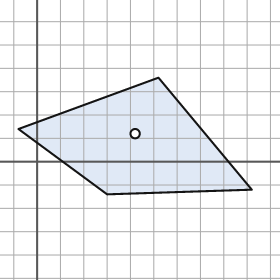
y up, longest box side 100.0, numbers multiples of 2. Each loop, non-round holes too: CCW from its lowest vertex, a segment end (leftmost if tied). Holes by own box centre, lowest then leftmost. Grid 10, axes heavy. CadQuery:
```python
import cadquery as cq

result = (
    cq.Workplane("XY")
    .moveTo(30.0, -14.0)
    .lineTo(92.0, -12.0)
    .lineTo(52.0, 36.0)
    .lineTo(-8.0, 14.0)
    .close()
    .moveTo(42.0, 12.0)
    .circle(2.0)
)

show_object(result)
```